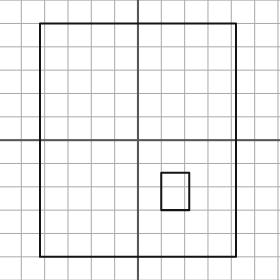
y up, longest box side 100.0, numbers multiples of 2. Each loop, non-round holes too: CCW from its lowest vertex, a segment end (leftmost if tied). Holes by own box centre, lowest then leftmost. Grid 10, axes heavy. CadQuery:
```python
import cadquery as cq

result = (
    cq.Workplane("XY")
    .moveTo(-42.0, -50.0)
    .lineTo(42.0, -50.0)
    .lineTo(42.0, 50.0)
    .lineTo(-42.0, 50.0)
    .close()
    .moveTo(10.0, -30.0)
    .lineTo(22.0, -30.0)
    .lineTo(22.0, -14.0)
    .lineTo(10.0, -14.0)
    .close()
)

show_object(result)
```